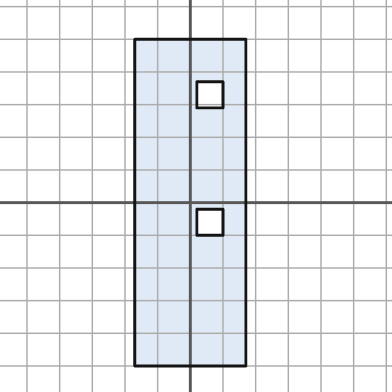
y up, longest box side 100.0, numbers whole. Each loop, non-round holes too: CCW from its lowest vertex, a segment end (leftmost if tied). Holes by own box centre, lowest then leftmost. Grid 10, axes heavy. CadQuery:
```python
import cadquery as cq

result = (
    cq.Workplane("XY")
    .moveTo(-17.0, -50.0)
    .lineTo(17.0, -50.0)
    .lineTo(17.0, 50.0)
    .lineTo(-17.0, 50.0)
    .close()
    .moveTo(2.0, -10.0)
    .lineTo(10.0, -10.0)
    .lineTo(10.0, -2.0)
    .lineTo(2.0, -2.0)
    .close()
    .moveTo(2.0, 29.0)
    .lineTo(10.0, 29.0)
    .lineTo(10.0, 37.0)
    .lineTo(2.0, 37.0)
    .close()
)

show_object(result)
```